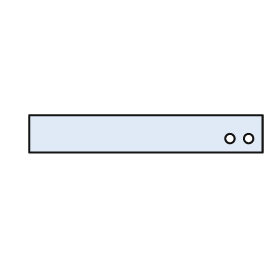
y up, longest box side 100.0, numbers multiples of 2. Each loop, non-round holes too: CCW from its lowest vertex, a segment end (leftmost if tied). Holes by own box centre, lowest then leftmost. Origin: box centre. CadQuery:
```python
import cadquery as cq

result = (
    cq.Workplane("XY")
    .moveTo(-50.0, -8.0)
    .lineTo(50.0, -8.0)
    .lineTo(50.0, 8.0)
    .lineTo(-50.0, 8.0)
    .close()
    .moveTo(36.0, -2.0)
    .circle(2.0)
    .moveTo(44.0, -2.0)
    .circle(2.0)
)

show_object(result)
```